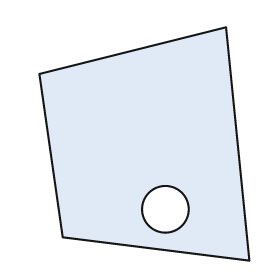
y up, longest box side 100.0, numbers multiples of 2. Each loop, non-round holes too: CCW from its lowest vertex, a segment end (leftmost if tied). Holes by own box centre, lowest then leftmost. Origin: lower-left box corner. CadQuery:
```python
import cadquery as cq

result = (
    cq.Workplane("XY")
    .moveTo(90.0, 0.0)
    .lineTo(80.0, 100.0)
    .lineTo(0.0, 80.0)
    .lineTo(10.0, 10.0)
    .close()
    .moveTo(54.0, 22.0)
    .circle(10.0)
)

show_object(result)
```